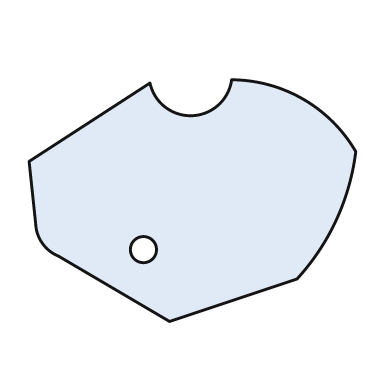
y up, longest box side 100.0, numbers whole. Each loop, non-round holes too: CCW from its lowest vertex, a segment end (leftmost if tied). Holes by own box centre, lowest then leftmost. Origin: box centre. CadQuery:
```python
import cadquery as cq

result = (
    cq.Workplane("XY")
    .moveTo(-7.0, -37.0)
    .lineTo(32.0, -24.0)
    .threePointArc((44.0, -6.0), (50.0, 15.0))
    .threePointArc((34.0, 31.0), (12.0, 37.0))
    .threePointArc((0.0, 26.0), (-13.0, 36.0))
    .lineTo(-50.0, 12.0)
    .lineTo(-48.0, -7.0)
    .threePointArc((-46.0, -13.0), (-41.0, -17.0))
    .close()
    .moveTo(-15.0, -15.0)
    .circle(4.0)
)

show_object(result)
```